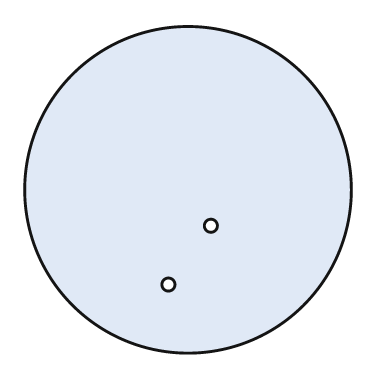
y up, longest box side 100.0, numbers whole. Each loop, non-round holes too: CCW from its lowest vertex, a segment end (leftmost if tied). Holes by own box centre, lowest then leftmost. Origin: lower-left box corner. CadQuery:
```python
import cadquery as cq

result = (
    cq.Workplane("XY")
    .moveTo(50.0, 50.0)
    .circle(50.0)
    .moveTo(44.0, 21.0)
    .circle(2.0)
    .moveTo(57.0, 39.0)
    .circle(2.0)
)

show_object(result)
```